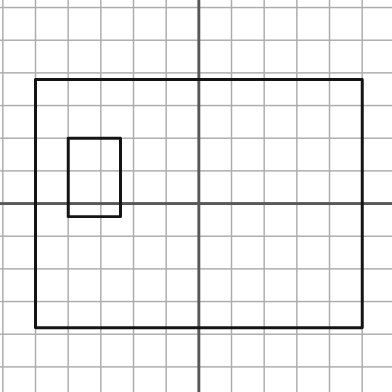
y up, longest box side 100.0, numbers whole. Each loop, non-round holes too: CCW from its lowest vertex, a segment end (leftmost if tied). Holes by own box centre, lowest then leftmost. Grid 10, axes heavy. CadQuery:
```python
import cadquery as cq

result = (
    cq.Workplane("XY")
    .moveTo(-50.0, -38.0)
    .lineTo(50.0, -38.0)
    .lineTo(50.0, 38.0)
    .lineTo(-50.0, 38.0)
    .close()
    .moveTo(-40.0, -4.0)
    .lineTo(-24.0, -4.0)
    .lineTo(-24.0, 20.0)
    .lineTo(-40.0, 20.0)
    .close()
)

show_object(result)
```